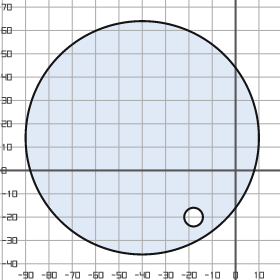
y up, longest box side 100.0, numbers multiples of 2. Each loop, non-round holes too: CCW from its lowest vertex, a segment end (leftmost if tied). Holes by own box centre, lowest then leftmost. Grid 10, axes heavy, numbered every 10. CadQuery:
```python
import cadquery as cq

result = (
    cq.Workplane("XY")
    .moveTo(-40.0, 14.0)
    .circle(50.0)
    .moveTo(-18.0, -20.0)
    .circle(4.0)
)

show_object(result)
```